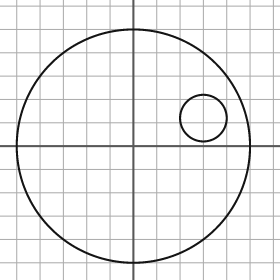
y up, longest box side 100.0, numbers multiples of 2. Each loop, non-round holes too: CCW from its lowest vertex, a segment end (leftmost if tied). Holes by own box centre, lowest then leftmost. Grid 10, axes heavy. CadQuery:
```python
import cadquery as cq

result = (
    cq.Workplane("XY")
    .moveTo(0.0, 0.0)
    .circle(50.0)
    .moveTo(30.0, 12.0)
    .circle(10.0)
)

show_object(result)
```